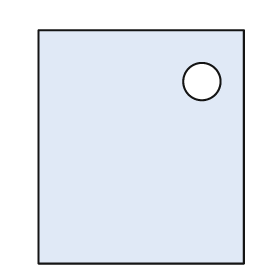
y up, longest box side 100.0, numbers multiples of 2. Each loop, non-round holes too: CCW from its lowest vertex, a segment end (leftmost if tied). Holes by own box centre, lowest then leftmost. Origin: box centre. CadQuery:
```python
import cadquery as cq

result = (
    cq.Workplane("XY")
    .moveTo(-44.0, -50.0)
    .lineTo(44.0, -50.0)
    .lineTo(44.0, 50.0)
    .lineTo(-44.0, 50.0)
    .close()
    .moveTo(26.0, 28.0)
    .circle(8.0)
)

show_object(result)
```